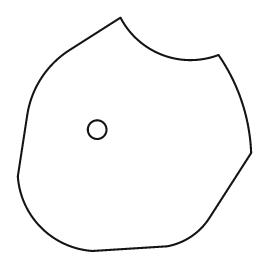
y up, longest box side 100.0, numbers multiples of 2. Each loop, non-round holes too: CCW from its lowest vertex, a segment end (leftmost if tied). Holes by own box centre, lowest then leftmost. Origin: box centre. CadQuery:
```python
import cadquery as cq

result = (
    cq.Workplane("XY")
    .moveTo(-18.0, -50.0)
    .lineTo(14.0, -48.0)
    .threePointArc((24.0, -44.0), (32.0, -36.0))
    .lineTo(50.0, -8.0)
    .threePointArc((46.0, 14.0), (36.0, 34.0))
    .threePointArc((12.0, 34.0), (-6.0, 50.0))
    .lineTo(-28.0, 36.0)
    .threePointArc((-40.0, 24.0), (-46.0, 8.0))
    .lineTo(-50.0, -18.0)
    .threePointArc((-40.0, -40.0), (-18.0, -50.0))
    .close()
    .moveTo(-16.0, 2.0)
    .circle(4.0)
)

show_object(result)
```